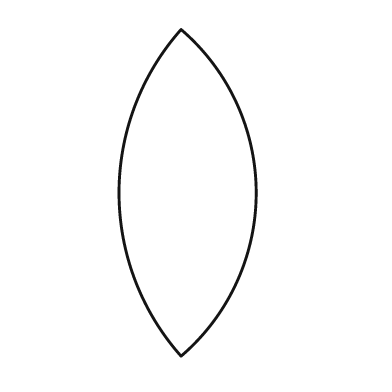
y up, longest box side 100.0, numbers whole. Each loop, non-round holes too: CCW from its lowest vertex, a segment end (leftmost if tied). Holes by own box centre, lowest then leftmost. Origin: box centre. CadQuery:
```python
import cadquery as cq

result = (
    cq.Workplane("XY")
    .moveTo(-2.0, -50.0)
    .threePointArc((21.0, 0.0), (-2.0, 50.0))
    .threePointArc((-21.0, 0.0), (-2.0, -50.0))
    .close()
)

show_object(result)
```